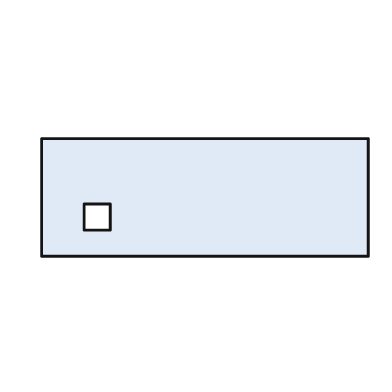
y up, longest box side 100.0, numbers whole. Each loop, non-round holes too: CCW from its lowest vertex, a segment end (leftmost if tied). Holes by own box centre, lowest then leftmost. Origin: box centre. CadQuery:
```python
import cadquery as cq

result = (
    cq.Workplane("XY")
    .moveTo(-50.0, -18.0)
    .lineTo(50.0, -18.0)
    .lineTo(50.0, 18.0)
    .lineTo(-50.0, 18.0)
    .close()
    .moveTo(-37.0, -10.0)
    .lineTo(-29.0, -10.0)
    .lineTo(-29.0, -2.0)
    .lineTo(-37.0, -2.0)
    .close()
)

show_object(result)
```